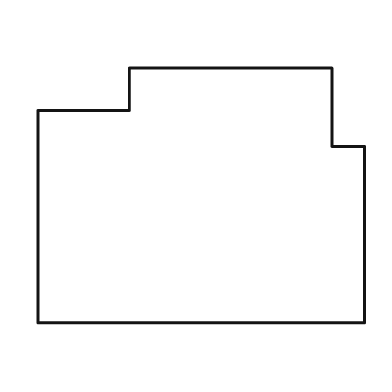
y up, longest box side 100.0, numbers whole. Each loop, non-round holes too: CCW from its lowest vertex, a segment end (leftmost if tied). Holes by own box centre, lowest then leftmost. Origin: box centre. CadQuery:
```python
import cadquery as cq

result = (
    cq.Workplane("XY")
    .moveTo(-50.0, -39.0)
    .lineTo(50.0, -39.0)
    .lineTo(50.0, 15.0)
    .lineTo(40.0, 15.0)
    .lineTo(40.0, 39.0)
    .lineTo(-22.0, 39.0)
    .lineTo(-22.0, 26.0)
    .lineTo(-50.0, 26.0)
    .close()
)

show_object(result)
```